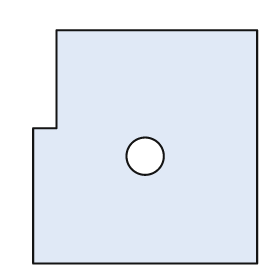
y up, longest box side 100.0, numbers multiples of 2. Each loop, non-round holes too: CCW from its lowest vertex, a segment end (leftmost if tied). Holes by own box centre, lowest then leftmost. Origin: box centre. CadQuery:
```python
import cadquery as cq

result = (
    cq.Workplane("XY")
    .moveTo(-48.0, -50.0)
    .lineTo(48.0, -50.0)
    .lineTo(48.0, 50.0)
    .lineTo(-38.0, 50.0)
    .lineTo(-38.0, 8.0)
    .lineTo(-48.0, 8.0)
    .close()
    .moveTo(0.0, -4.0)
    .circle(8.0)
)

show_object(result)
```